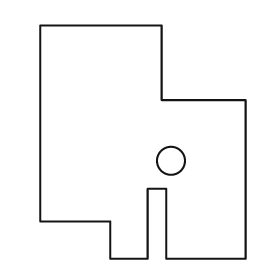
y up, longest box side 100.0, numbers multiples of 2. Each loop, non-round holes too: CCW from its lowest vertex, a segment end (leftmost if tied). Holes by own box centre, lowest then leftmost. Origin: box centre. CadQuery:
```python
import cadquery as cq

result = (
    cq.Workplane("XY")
    .moveTo(-14.0, -50.0)
    .lineTo(2.0, -50.0)
    .lineTo(2.0, -20.0)
    .lineTo(10.0, -20.0)
    .lineTo(10.0, -50.0)
    .lineTo(44.0, -50.0)
    .lineTo(44.0, 18.0)
    .lineTo(8.0, 18.0)
    .lineTo(8.0, 50.0)
    .lineTo(-44.0, 50.0)
    .lineTo(-44.0, -34.0)
    .lineTo(-14.0, -34.0)
    .close()
    .moveTo(12.0, -8.0)
    .circle(6.0)
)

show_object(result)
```